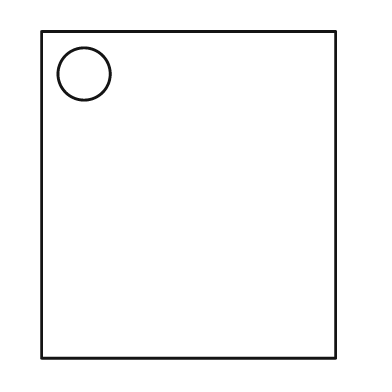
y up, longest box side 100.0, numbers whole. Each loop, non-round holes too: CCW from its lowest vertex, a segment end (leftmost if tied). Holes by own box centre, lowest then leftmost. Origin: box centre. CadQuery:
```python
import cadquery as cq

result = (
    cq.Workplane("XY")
    .moveTo(-45.0, -50.0)
    .lineTo(45.0, -50.0)
    .lineTo(45.0, 50.0)
    .lineTo(-45.0, 50.0)
    .close()
    .moveTo(-32.0, 37.0)
    .circle(8.0)
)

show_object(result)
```